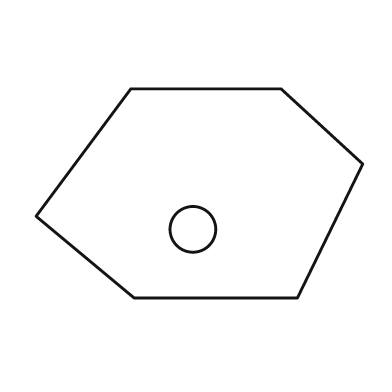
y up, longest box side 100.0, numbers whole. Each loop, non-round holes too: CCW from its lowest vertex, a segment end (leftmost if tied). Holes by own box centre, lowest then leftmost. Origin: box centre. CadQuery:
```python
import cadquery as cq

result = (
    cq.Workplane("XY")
    .moveTo(-20.0, -32.0)
    .lineTo(30.0, -32.0)
    .lineTo(50.0, 9.0)
    .lineTo(25.0, 32.0)
    .lineTo(-21.0, 32.0)
    .lineTo(-50.0, -7.0)
    .close()
    .moveTo(-2.0, -11.0)
    .circle(7.0)
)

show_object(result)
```